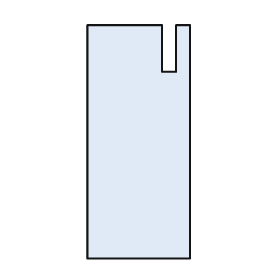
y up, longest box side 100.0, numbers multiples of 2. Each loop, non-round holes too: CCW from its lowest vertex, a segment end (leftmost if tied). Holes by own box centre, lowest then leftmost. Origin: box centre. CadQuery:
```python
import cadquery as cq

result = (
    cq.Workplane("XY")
    .moveTo(-22.0, -50.0)
    .lineTo(22.0, -50.0)
    .lineTo(22.0, 50.0)
    .lineTo(16.0, 50.0)
    .lineTo(16.0, 30.0)
    .lineTo(10.0, 30.0)
    .lineTo(10.0, 50.0)
    .lineTo(-22.0, 50.0)
    .close()
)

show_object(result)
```